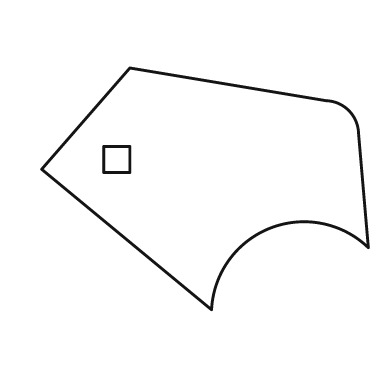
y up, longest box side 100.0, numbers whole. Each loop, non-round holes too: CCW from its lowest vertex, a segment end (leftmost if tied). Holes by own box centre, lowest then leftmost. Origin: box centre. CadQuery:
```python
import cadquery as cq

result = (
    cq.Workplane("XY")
    .moveTo(2.0, -37.0)
    .threePointArc((20.0, -12.0), (50.0, -18.0))
    .lineTo(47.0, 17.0)
    .threePointArc((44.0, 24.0), (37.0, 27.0))
    .lineTo(-23.0, 37.0)
    .lineTo(-50.0, 6.0)
    .close()
    .moveTo(-31.0, 5.0)
    .lineTo(-23.0, 5.0)
    .lineTo(-23.0, 13.0)
    .lineTo(-31.0, 13.0)
    .close()
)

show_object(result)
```